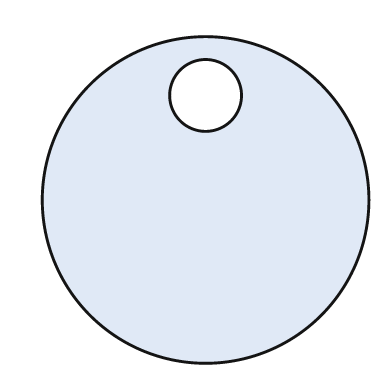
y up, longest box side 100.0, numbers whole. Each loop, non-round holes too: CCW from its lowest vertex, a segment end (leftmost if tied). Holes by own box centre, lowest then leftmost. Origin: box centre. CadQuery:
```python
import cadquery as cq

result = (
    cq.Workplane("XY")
    .moveTo(0.0, 0.0)
    .circle(50.0)
    .moveTo(0.0, 32.0)
    .circle(11.0)
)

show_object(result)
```